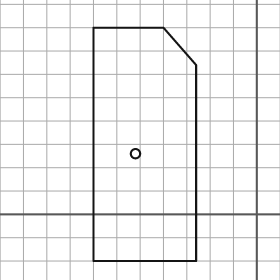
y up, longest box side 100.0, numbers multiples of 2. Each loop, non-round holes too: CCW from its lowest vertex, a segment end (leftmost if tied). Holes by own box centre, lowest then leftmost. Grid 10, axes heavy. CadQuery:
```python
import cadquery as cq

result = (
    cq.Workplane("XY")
    .moveTo(-70.0, -20.0)
    .lineTo(-26.0, -20.0)
    .lineTo(-26.0, 64.0)
    .lineTo(-40.0, 80.0)
    .lineTo(-70.0, 80.0)
    .close()
    .moveTo(-52.0, 26.0)
    .circle(2.0)
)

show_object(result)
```